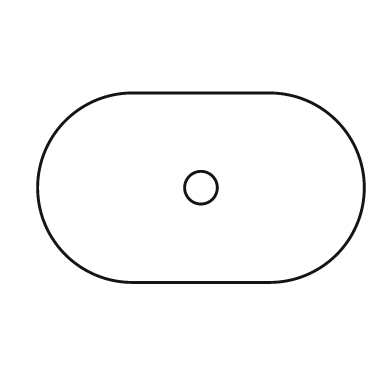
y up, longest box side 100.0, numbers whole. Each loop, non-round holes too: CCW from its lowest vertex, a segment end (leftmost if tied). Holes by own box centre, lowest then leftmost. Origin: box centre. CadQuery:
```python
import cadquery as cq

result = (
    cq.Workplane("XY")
    .moveTo(-21.0, -29.0)
    .lineTo(21.0, -29.0)
    .threePointArc((50.0, 0.0), (21.0, 29.0))
    .lineTo(-21.0, 29.0)
    .threePointArc((-50.0, 0.0), (-21.0, -29.0))
    .close()
    .moveTo(0.0, 0.0)
    .circle(5.0)
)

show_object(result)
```